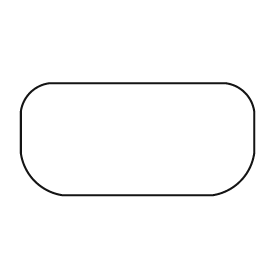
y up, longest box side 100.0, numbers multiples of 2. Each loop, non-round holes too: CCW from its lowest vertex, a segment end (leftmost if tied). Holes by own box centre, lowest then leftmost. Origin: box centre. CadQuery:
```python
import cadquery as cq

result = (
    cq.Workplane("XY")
    .moveTo(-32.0, -24.0)
    .lineTo(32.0, -24.0)
    .threePointArc((44.0, -18.0), (50.0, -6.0))
    .lineTo(50.0, 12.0)
    .threePointArc((46.0, 20.0), (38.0, 24.0))
    .lineTo(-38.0, 24.0)
    .threePointArc((-46.0, 20.0), (-50.0, 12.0))
    .lineTo(-50.0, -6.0)
    .threePointArc((-44.0, -18.0), (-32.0, -24.0))
    .close()
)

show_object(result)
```